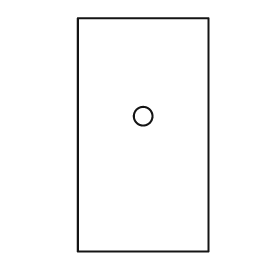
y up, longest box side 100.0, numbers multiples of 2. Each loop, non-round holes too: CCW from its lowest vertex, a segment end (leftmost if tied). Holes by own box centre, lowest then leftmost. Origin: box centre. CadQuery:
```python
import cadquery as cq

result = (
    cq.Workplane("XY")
    .moveTo(-28.0, -50.0)
    .lineTo(28.0, -50.0)
    .lineTo(28.0, 50.0)
    .lineTo(-28.0, 50.0)
    .close()
    .moveTo(0.0, 8.0)
    .circle(4.0)
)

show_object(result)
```